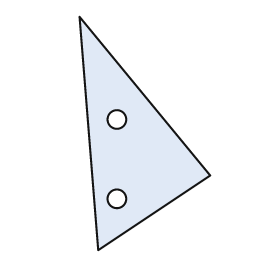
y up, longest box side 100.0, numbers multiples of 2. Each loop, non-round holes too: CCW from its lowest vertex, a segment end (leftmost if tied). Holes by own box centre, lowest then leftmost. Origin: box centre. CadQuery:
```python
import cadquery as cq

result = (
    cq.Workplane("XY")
    .moveTo(-20.0, -50.0)
    .lineTo(28.0, -18.0)
    .lineTo(-28.0, 50.0)
    .close()
    .moveTo(-12.0, -28.0)
    .circle(4.0)
    .moveTo(-12.0, 6.0)
    .circle(4.0)
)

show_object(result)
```